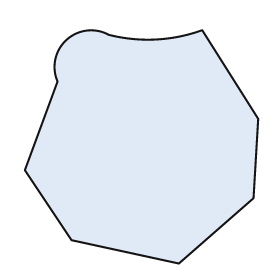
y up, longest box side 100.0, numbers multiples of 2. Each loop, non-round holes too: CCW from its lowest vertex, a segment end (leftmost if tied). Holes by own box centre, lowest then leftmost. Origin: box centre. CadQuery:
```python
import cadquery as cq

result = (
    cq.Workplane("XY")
    .moveTo(16.0, -50.0)
    .lineTo(48.0, -22.0)
    .lineTo(50.0, 12.0)
    .lineTo(26.0, 50.0)
    .threePointArc((6.0, 46.0), (-14.0, 48.0))
    .threePointArc((-32.0, 46.0), (-36.0, 28.0))
    .lineTo(-50.0, -10.0)
    .lineTo(-30.0, -40.0)
    .close()
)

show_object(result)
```